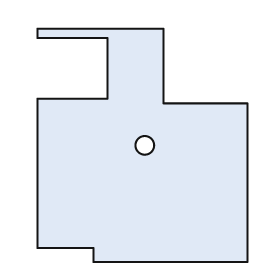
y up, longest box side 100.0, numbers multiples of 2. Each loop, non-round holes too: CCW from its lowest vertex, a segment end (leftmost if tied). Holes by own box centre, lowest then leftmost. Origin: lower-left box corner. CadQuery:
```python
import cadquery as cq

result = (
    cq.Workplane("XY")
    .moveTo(24.0, 0.0)
    .lineTo(90.0, 0.0)
    .lineTo(90.0, 68.0)
    .lineTo(54.0, 68.0)
    .lineTo(54.0, 100.0)
    .lineTo(0.0, 100.0)
    .lineTo(0.0, 96.0)
    .lineTo(30.0, 96.0)
    .lineTo(30.0, 70.0)
    .lineTo(0.0, 70.0)
    .lineTo(0.0, 6.0)
    .lineTo(24.0, 6.0)
    .close()
    .moveTo(46.0, 50.0)
    .circle(4.0)
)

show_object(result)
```